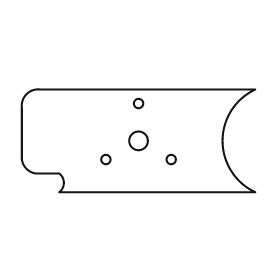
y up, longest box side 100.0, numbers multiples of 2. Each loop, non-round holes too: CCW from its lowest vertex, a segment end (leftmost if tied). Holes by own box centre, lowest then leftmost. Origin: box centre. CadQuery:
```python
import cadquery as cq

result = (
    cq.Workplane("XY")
    .moveTo(-34.0, -22.0)
    .lineTo(50.0, -22.0)
    .threePointArc((36.0, 0.0), (50.0, 22.0))
    .lineTo(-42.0, 22.0)
    .threePointArc((-48.0, 20.0), (-50.0, 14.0))
    .lineTo(-50.0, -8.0)
    .threePointArc((-48.0, -12.0), (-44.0, -14.0))
    .lineTo(-34.0, -14.0)
    .threePointArc((-32.0, -18.0), (-34.0, -22.0))
    .close()
    .moveTo(-14.0, -8.0)
    .circle(2.0)
    .moveTo(14.0, -8.0)
    .circle(2.0)
    .moveTo(0.0, 0.0)
    .circle(4.0)
    .moveTo(0.0, 16.0)
    .circle(2.0)
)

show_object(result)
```